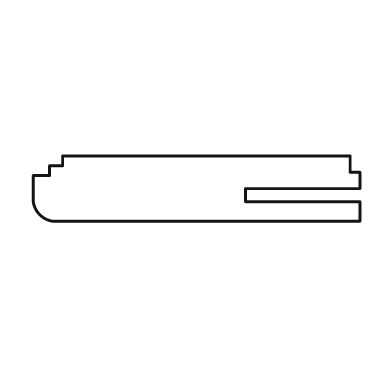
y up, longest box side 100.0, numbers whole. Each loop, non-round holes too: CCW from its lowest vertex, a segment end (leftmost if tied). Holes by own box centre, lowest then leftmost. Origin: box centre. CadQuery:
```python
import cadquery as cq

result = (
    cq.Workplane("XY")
    .moveTo(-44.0, -10.0)
    .lineTo(50.0, -10.0)
    .lineTo(50.0, -4.0)
    .lineTo(15.0, -4.0)
    .lineTo(15.0, 0.0)
    .lineTo(50.0, 0.0)
    .lineTo(50.0, 5.0)
    .lineTo(47.0, 5.0)
    .lineTo(47.0, 10.0)
    .lineTo(-41.0, 10.0)
    .lineTo(-41.0, 7.0)
    .lineTo(-45.0, 7.0)
    .lineTo(-45.0, 4.0)
    .lineTo(-50.0, 4.0)
    .lineTo(-50.0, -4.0)
    .threePointArc((-48.0, -8.0), (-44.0, -10.0))
    .close()
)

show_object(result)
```